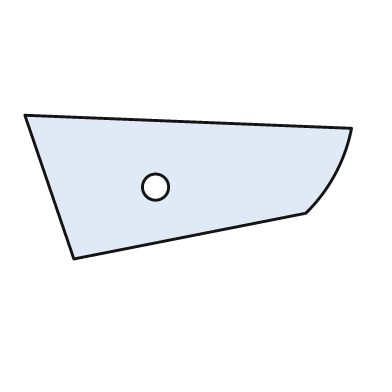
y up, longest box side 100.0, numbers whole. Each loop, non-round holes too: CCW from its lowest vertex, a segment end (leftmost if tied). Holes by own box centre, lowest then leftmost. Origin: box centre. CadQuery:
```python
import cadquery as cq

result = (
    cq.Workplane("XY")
    .moveTo(-35.0, -22.0)
    .lineTo(36.0, -8.0)
    .threePointArc((45.0, 4.0), (50.0, 18.0))
    .lineTo(-50.0, 22.0)
    .close()
    .moveTo(-10.0, 0.0)
    .circle(4.0)
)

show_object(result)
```